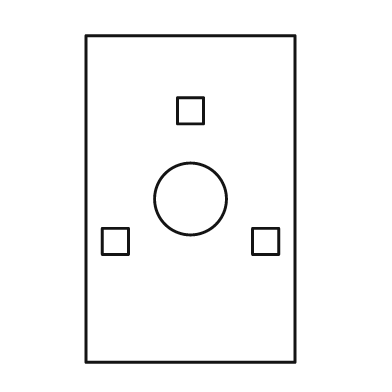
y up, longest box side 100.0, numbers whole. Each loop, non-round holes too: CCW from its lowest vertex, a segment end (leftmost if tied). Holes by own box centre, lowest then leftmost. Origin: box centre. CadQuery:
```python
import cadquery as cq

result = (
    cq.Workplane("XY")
    .moveTo(-32.0, -50.0)
    .lineTo(32.0, -50.0)
    .lineTo(32.0, 50.0)
    .lineTo(-32.0, 50.0)
    .close()
    .moveTo(-27.0, -17.0)
    .lineTo(-19.0, -17.0)
    .lineTo(-19.0, -9.0)
    .lineTo(-27.0, -9.0)
    .close()
    .moveTo(19.0, -17.0)
    .lineTo(27.0, -17.0)
    .lineTo(27.0, -9.0)
    .lineTo(19.0, -9.0)
    .close()
    .moveTo(0.0, 0.0)
    .circle(11.0)
    .moveTo(-4.0, 23.0)
    .lineTo(4.0, 23.0)
    .lineTo(4.0, 31.0)
    .lineTo(-4.0, 31.0)
    .close()
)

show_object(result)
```